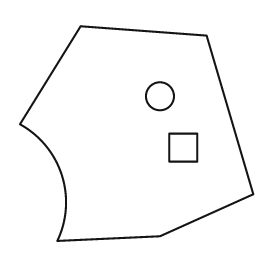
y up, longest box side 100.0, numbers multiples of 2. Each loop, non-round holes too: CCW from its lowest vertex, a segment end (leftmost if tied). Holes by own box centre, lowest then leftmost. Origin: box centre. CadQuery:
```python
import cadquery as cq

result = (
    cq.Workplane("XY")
    .moveTo(-34.0, -46.0)
    .lineTo(10.0, -44.0)
    .lineTo(50.0, -26.0)
    .lineTo(30.0, 42.0)
    .lineTo(-24.0, 46.0)
    .lineTo(-50.0, 4.0)
    .threePointArc((-32.0, -18.0), (-34.0, -46.0))
    .close()
    .moveTo(14.0, -12.0)
    .lineTo(26.0, -12.0)
    .lineTo(26.0, 0.0)
    .lineTo(14.0, 0.0)
    .close()
    .moveTo(10.0, 16.0)
    .circle(6.0)
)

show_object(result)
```